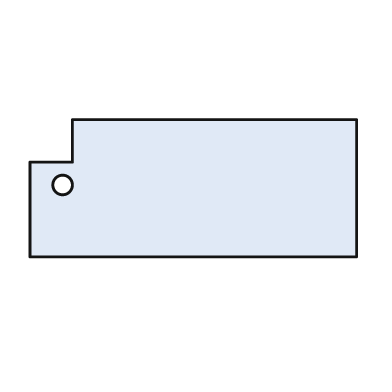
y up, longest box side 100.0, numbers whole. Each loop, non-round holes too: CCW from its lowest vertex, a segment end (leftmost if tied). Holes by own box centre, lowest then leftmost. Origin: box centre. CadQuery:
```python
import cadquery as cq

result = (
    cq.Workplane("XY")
    .moveTo(-50.0, -21.0)
    .lineTo(50.0, -21.0)
    .lineTo(50.0, 21.0)
    .lineTo(-37.0, 21.0)
    .lineTo(-37.0, 8.0)
    .lineTo(-50.0, 8.0)
    .close()
    .moveTo(-40.0, 1.0)
    .circle(3.0)
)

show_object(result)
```